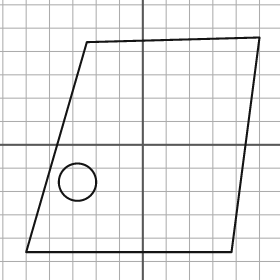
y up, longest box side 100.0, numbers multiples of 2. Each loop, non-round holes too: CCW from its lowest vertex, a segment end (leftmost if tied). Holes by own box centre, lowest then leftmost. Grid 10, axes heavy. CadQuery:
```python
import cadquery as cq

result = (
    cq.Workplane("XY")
    .moveTo(-50.0, -46.0)
    .lineTo(38.0, -46.0)
    .lineTo(50.0, 46.0)
    .lineTo(-24.0, 44.0)
    .close()
    .moveTo(-28.0, -16.0)
    .circle(8.0)
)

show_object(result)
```